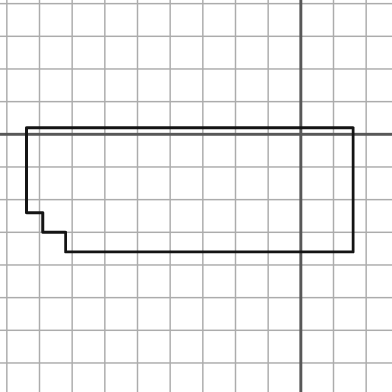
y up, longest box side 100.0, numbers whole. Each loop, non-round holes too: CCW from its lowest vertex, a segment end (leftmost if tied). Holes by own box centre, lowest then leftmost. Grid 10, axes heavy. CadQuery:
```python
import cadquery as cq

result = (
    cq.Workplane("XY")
    .moveTo(-72.0, -36.0)
    .lineTo(16.0, -36.0)
    .lineTo(16.0, 2.0)
    .lineTo(-84.0, 2.0)
    .lineTo(-84.0, -24.0)
    .lineTo(-79.0, -24.0)
    .lineTo(-79.0, -30.0)
    .lineTo(-72.0, -30.0)
    .close()
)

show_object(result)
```